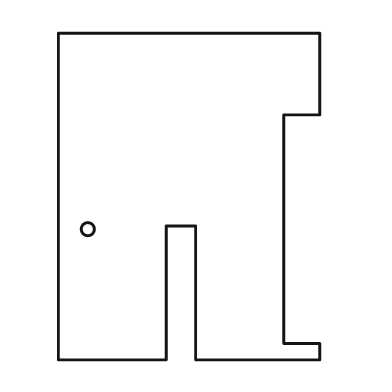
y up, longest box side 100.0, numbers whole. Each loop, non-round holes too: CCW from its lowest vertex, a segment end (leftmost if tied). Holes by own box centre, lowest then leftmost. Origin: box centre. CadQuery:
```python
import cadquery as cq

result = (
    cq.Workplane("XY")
    .moveTo(-40.0, -50.0)
    .lineTo(-7.0, -50.0)
    .lineTo(-7.0, -9.0)
    .lineTo(2.0, -9.0)
    .lineTo(2.0, -50.0)
    .lineTo(40.0, -50.0)
    .lineTo(40.0, -45.0)
    .lineTo(29.0, -45.0)
    .lineTo(29.0, 25.0)
    .lineTo(40.0, 25.0)
    .lineTo(40.0, 50.0)
    .lineTo(-40.0, 50.0)
    .close()
    .moveTo(-31.0, -10.0)
    .circle(2.0)
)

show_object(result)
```